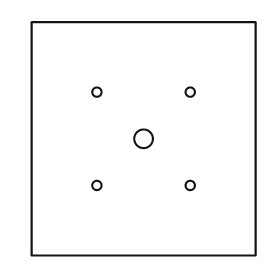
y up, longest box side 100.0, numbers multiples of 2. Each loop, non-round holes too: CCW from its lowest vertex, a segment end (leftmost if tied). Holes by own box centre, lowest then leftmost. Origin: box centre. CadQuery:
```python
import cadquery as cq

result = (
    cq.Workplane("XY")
    .moveTo(-48.0, -50.0)
    .lineTo(48.0, -50.0)
    .lineTo(48.0, 50.0)
    .lineTo(-48.0, 50.0)
    .close()
    .moveTo(-20.0, -20.0)
    .circle(2.0)
    .moveTo(20.0, -20.0)
    .circle(2.0)
    .moveTo(0.0, 0.0)
    .circle(4.0)
    .moveTo(-20.0, 20.0)
    .circle(2.0)
    .moveTo(20.0, 20.0)
    .circle(2.0)
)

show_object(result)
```